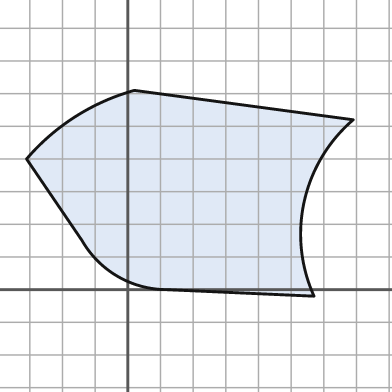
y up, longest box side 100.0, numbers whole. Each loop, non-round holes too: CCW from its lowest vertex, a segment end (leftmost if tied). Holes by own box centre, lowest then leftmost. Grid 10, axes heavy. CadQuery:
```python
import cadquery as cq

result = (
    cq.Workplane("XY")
    .moveTo(57.0, -2.0)
    .threePointArc((54.0, 27.0), (69.0, 52.0))
    .lineTo(2.0, 61.0)
    .threePointArc((-16.0, 53.0), (-31.0, 40.0))
    .lineTo(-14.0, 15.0)
    .threePointArc((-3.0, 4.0), (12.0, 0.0))
    .close()
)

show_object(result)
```